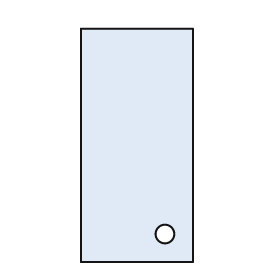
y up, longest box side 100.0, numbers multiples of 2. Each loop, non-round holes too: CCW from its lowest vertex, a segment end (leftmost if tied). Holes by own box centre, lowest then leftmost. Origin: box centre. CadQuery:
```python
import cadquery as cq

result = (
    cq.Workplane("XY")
    .moveTo(-24.0, -50.0)
    .lineTo(24.0, -50.0)
    .lineTo(24.0, 50.0)
    .lineTo(-24.0, 50.0)
    .close()
    .moveTo(12.0, -38.0)
    .circle(4.0)
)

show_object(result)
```